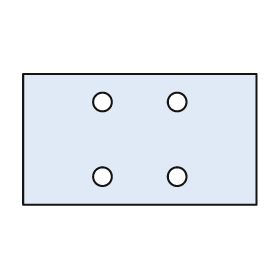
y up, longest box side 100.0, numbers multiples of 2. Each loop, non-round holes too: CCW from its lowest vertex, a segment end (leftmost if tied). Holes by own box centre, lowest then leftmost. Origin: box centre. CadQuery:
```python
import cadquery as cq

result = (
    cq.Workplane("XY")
    .moveTo(-50.0, -28.0)
    .lineTo(50.0, -28.0)
    .lineTo(50.0, 28.0)
    .lineTo(-50.0, 28.0)
    .close()
    .moveTo(-16.0, -16.0)
    .circle(4.0)
    .moveTo(16.0, -16.0)
    .circle(4.0)
    .moveTo(-16.0, 16.0)
    .circle(4.0)
    .moveTo(16.0, 16.0)
    .circle(4.0)
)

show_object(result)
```